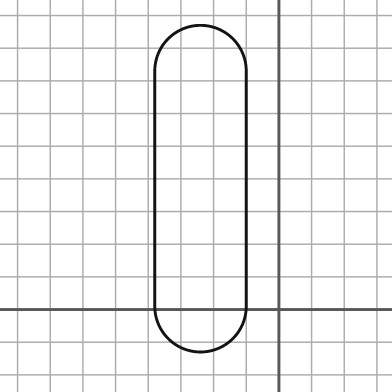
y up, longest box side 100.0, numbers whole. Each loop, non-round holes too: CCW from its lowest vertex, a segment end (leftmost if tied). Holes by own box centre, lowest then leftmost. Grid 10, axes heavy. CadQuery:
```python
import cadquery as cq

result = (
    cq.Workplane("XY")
    .moveTo(-38.0, 1.0)
    .threePointArc((-24.0, -13.0), (-10.0, 1.0))
    .lineTo(-10.0, 73.0)
    .threePointArc((-24.0, 87.0), (-38.0, 73.0))
    .close()
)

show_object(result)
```